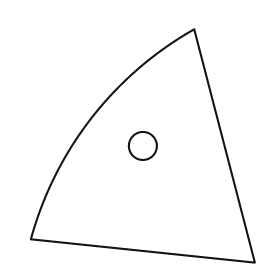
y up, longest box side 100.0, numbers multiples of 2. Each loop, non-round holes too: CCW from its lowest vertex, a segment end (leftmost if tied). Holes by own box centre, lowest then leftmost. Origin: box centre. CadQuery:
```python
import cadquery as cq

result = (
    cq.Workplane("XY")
    .moveTo(48.0, -50.0)
    .lineTo(22.0, 50.0)
    .threePointArc((-22.0, 12.0), (-48.0, -40.0))
    .close()
    .moveTo(0.0, 0.0)
    .circle(6.0)
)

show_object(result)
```